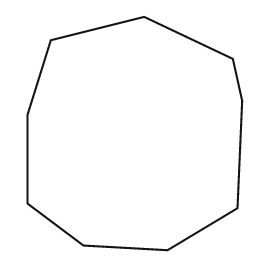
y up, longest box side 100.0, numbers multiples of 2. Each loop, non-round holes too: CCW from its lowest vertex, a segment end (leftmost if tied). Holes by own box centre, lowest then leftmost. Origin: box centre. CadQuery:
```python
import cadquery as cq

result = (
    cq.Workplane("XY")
    .moveTo(14.0, -50.0)
    .lineTo(44.0, -32.0)
    .lineTo(46.0, 14.0)
    .lineTo(42.0, 32.0)
    .lineTo(4.0, 50.0)
    .lineTo(-36.0, 40.0)
    .lineTo(-46.0, 8.0)
    .lineTo(-46.0, -30.0)
    .lineTo(-22.0, -48.0)
    .close()
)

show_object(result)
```